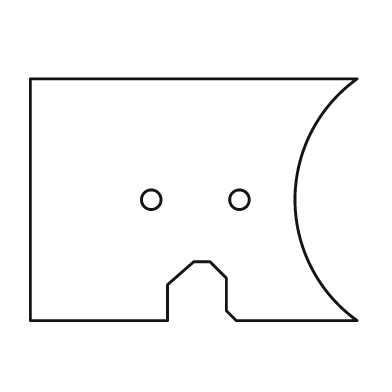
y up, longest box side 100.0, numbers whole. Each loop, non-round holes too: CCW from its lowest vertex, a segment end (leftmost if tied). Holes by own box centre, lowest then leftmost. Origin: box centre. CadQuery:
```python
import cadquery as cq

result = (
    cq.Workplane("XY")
    .moveTo(-50.0, -37.0)
    .lineTo(-8.0, -37.0)
    .lineTo(-8.0, -26.0)
    .lineTo(0.0, -19.0)
    .lineTo(5.0, -19.0)
    .lineTo(10.0, -24.0)
    .lineTo(10.0, -34.0)
    .lineTo(13.0, -37.0)
    .lineTo(50.0, -37.0)
    .threePointArc((31.0, 0.0), (50.0, 37.0))
    .lineTo(-50.0, 37.0)
    .close()
    .moveTo(-13.0, 0.0)
    .circle(3.0)
    .moveTo(14.0, 0.0)
    .circle(3.0)
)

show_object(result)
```